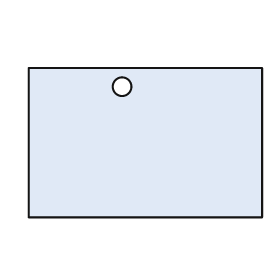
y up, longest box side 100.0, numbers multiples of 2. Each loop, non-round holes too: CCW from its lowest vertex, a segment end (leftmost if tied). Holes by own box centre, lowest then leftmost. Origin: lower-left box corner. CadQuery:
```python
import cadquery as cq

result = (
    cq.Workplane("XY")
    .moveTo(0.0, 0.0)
    .lineTo(100.0, 0.0)
    .lineTo(100.0, 64.0)
    .lineTo(0.0, 64.0)
    .close()
    .moveTo(40.0, 56.0)
    .circle(4.0)
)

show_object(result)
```